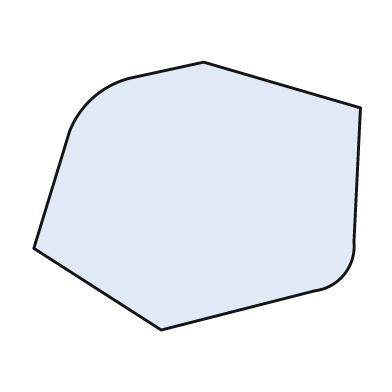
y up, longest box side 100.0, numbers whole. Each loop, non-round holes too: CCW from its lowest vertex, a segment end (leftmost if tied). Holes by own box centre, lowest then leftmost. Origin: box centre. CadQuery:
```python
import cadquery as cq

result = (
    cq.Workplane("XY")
    .moveTo(-11.0, -41.0)
    .lineTo(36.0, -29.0)
    .threePointArc((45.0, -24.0), (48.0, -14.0))
    .lineTo(50.0, 27.0)
    .lineTo(2.0, 41.0)
    .lineTo(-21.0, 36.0)
    .threePointArc((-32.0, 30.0), (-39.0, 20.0))
    .lineTo(-50.0, -16.0)
    .close()
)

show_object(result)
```